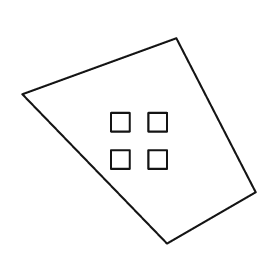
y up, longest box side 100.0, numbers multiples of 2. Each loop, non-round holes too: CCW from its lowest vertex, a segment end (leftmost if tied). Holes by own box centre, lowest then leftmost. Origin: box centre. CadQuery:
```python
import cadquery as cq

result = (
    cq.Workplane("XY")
    .moveTo(12.0, -44.0)
    .lineTo(50.0, -22.0)
    .lineTo(16.0, 44.0)
    .lineTo(-50.0, 20.0)
    .close()
    .moveTo(-12.0, -12.0)
    .lineTo(-4.0, -12.0)
    .lineTo(-4.0, -4.0)
    .lineTo(-12.0, -4.0)
    .close()
    .moveTo(4.0, -12.0)
    .lineTo(12.0, -12.0)
    .lineTo(12.0, -4.0)
    .lineTo(4.0, -4.0)
    .close()
    .moveTo(-12.0, 4.0)
    .lineTo(-4.0, 4.0)
    .lineTo(-4.0, 12.0)
    .lineTo(-12.0, 12.0)
    .close()
    .moveTo(4.0, 4.0)
    .lineTo(12.0, 4.0)
    .lineTo(12.0, 12.0)
    .lineTo(4.0, 12.0)
    .close()
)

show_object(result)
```